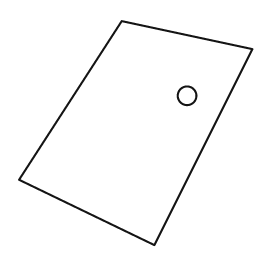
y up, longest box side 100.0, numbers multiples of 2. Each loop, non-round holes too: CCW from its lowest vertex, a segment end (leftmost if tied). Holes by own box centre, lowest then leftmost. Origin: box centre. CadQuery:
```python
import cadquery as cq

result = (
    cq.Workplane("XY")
    .moveTo(8.0, -48.0)
    .lineTo(50.0, 36.0)
    .lineTo(-6.0, 48.0)
    .lineTo(-50.0, -20.0)
    .close()
    .moveTo(22.0, 16.0)
    .circle(4.0)
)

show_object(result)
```